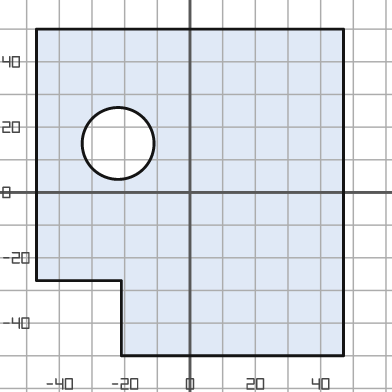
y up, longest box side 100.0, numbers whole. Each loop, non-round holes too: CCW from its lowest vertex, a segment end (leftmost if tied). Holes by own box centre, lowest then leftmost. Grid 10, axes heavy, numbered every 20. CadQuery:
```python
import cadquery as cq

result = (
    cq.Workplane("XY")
    .moveTo(-21.0, -50.0)
    .lineTo(47.0, -50.0)
    .lineTo(47.0, 50.0)
    .lineTo(-47.0, 50.0)
    .lineTo(-47.0, -27.0)
    .lineTo(-21.0, -27.0)
    .close()
    .moveTo(-22.0, 15.0)
    .circle(11.0)
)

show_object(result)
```